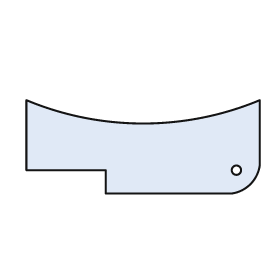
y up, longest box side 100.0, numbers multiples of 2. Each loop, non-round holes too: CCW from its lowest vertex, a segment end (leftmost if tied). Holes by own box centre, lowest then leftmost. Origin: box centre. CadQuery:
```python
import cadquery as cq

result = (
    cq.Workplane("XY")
    .moveTo(-16.0, -20.0)
    .lineTo(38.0, -20.0)
    .threePointArc((46.0, -16.0), (50.0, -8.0))
    .lineTo(50.0, 20.0)
    .threePointArc((0.0, 10.0), (-50.0, 20.0))
    .lineTo(-50.0, -10.0)
    .lineTo(-16.0, -10.0)
    .close()
    .moveTo(40.0, -10.0)
    .circle(2.0)
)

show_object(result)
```